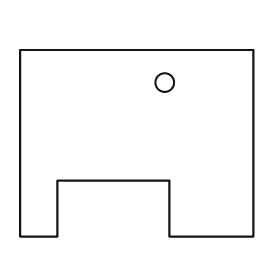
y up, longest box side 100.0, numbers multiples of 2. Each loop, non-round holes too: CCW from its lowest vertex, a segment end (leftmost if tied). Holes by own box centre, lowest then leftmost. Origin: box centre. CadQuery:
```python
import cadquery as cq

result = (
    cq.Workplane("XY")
    .moveTo(-50.0, -40.0)
    .lineTo(-34.0, -40.0)
    .lineTo(-34.0, -16.0)
    .lineTo(14.0, -16.0)
    .lineTo(14.0, -40.0)
    .lineTo(50.0, -40.0)
    .lineTo(50.0, 40.0)
    .lineTo(-50.0, 40.0)
    .close()
    .moveTo(12.0, 26.0)
    .circle(4.0)
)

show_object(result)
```